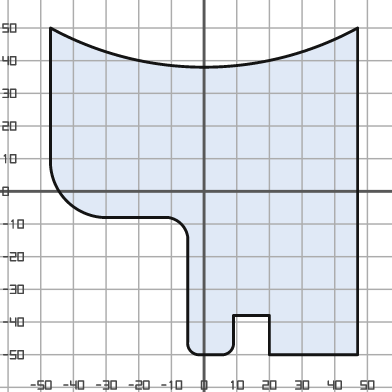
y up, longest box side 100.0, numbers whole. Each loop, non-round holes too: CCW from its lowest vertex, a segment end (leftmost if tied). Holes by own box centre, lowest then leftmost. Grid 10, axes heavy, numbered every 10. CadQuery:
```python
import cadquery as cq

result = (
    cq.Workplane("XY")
    .moveTo(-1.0, -50.0)
    .lineTo(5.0, -50.0)
    .threePointArc((8.0, -49.0), (9.0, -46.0))
    .lineTo(9.0, -38.0)
    .lineTo(20.0, -38.0)
    .lineTo(20.0, -50.0)
    .lineTo(47.0, -50.0)
    .lineTo(47.0, 50.0)
    .threePointArc((0.0, 38.0), (-47.0, 50.0))
    .lineTo(-47.0, 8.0)
    .threePointArc((-42.0, -3.0), (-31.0, -8.0))
    .lineTo(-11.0, -8.0)
    .threePointArc((-7.0, -10.0), (-5.0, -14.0))
    .lineTo(-5.0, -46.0)
    .threePointArc((-4.0, -49.0), (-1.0, -50.0))
    .close()
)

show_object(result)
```